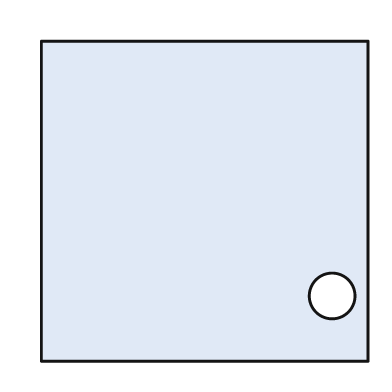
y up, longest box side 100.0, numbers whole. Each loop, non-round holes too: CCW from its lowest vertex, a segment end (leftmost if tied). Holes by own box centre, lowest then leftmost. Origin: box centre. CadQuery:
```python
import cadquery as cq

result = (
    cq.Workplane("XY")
    .moveTo(-50.0, -49.0)
    .lineTo(50.0, -49.0)
    .lineTo(50.0, 49.0)
    .lineTo(-50.0, 49.0)
    .close()
    .moveTo(39.0, -29.0)
    .circle(7.0)
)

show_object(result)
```